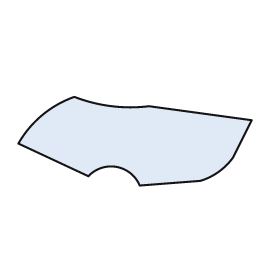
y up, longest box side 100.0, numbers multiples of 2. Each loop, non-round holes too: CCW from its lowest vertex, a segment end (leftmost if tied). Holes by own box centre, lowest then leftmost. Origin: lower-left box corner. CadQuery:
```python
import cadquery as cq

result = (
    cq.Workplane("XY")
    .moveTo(52.0, 0.0)
    .lineTo(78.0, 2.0)
    .threePointArc((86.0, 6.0), (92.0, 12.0))
    .lineTo(100.0, 28.0)
    .lineTo(56.0, 34.0)
    .threePointArc((40.0, 34.0), (24.0, 38.0))
    .threePointArc((10.0, 30.0), (0.0, 18.0))
    .lineTo(30.0, 4.0)
    .threePointArc((42.0, 8.0), (52.0, 0.0))
    .close()
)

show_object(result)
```